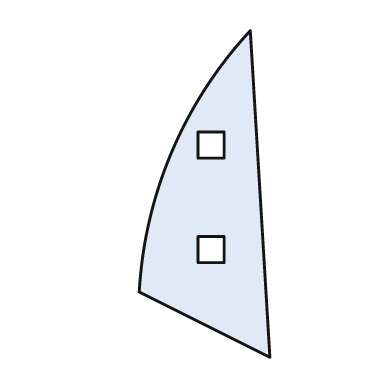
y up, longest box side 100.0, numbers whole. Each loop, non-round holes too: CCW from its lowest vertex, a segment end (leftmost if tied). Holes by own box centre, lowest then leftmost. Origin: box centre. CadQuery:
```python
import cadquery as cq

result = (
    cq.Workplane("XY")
    .moveTo(20.0, -50.0)
    .lineTo(14.0, 50.0)
    .threePointArc((-10.0, 13.0), (-20.0, -30.0))
    .close()
    .moveTo(-2.0, -21.0)
    .lineTo(6.0, -21.0)
    .lineTo(6.0, -13.0)
    .lineTo(-2.0, -13.0)
    .close()
    .moveTo(-2.0, 11.0)
    .lineTo(6.0, 11.0)
    .lineTo(6.0, 19.0)
    .lineTo(-2.0, 19.0)
    .close()
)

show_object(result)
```